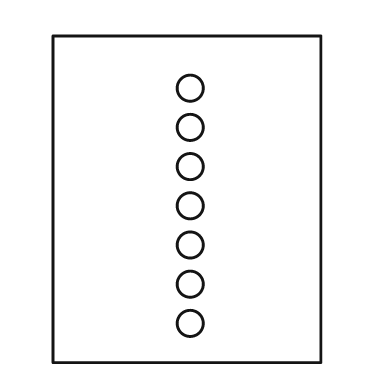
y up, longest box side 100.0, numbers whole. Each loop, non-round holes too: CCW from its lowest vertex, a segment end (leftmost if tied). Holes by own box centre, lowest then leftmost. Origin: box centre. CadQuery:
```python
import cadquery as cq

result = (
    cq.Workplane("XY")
    .moveTo(-41.0, -50.0)
    .lineTo(41.0, -50.0)
    .lineTo(41.0, 50.0)
    .lineTo(-41.0, 50.0)
    .close()
    .moveTo(1.0, -38.0)
    .circle(4.0)
    .moveTo(1.0, -26.0)
    .circle(4.0)
    .moveTo(1.0, -14.0)
    .circle(4.0)
    .moveTo(1.0, -2.0)
    .circle(4.0)
    .moveTo(1.0, 10.0)
    .circle(4.0)
    .moveTo(1.0, 22.0)
    .circle(4.0)
    .moveTo(1.0, 34.0)
    .circle(4.0)
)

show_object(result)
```